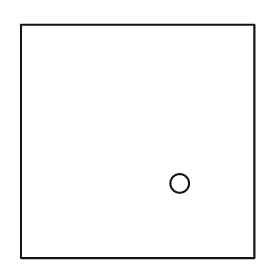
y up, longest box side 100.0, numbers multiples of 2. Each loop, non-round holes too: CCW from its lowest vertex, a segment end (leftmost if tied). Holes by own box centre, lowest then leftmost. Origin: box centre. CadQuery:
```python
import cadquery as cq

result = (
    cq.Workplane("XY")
    .moveTo(-50.0, -50.0)
    .lineTo(50.0, -50.0)
    .lineTo(50.0, 50.0)
    .lineTo(-50.0, 50.0)
    .close()
    .moveTo(18.0, -18.0)
    .circle(4.0)
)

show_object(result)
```